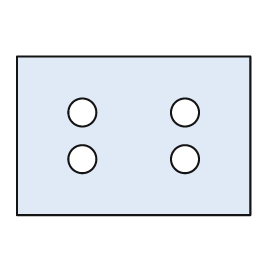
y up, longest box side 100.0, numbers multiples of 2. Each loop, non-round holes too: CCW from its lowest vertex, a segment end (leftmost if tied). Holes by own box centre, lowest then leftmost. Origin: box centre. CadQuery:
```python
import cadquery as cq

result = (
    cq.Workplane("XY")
    .moveTo(-50.0, -34.0)
    .lineTo(50.0, -34.0)
    .lineTo(50.0, 34.0)
    .lineTo(-50.0, 34.0)
    .close()
    .moveTo(-22.0, -10.0)
    .circle(6.0)
    .moveTo(22.0, -10.0)
    .circle(6.0)
    .moveTo(-22.0, 10.0)
    .circle(6.0)
    .moveTo(22.0, 10.0)
    .circle(6.0)
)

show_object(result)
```